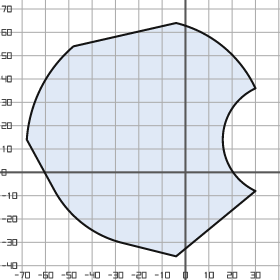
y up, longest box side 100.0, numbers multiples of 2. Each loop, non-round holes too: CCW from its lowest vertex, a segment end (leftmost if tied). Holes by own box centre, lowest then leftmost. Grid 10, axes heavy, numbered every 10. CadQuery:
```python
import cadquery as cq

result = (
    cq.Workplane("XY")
    .moveTo(-4.0, -36.0)
    .lineTo(30.0, -8.0)
    .threePointArc((16.0, 14.0), (30.0, 36.0))
    .threePointArc((16.0, 54.0), (-4.0, 64.0))
    .lineTo(-48.0, 54.0)
    .threePointArc((-62.0, 36.0), (-68.0, 14.0))
    .lineTo(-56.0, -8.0)
    .threePointArc((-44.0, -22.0), (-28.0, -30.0))
    .close()
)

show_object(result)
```